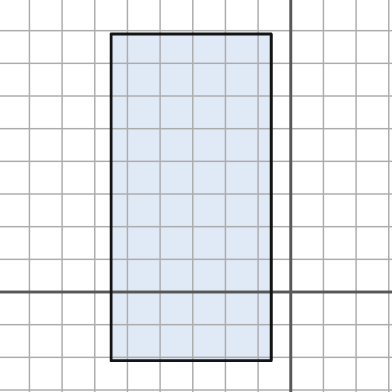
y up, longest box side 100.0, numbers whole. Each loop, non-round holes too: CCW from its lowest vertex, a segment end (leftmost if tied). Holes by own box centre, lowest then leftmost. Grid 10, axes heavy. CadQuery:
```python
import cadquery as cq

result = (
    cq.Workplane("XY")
    .moveTo(-55.0, -21.0)
    .lineTo(-6.0, -21.0)
    .lineTo(-6.0, 79.0)
    .lineTo(-55.0, 79.0)
    .close()
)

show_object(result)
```